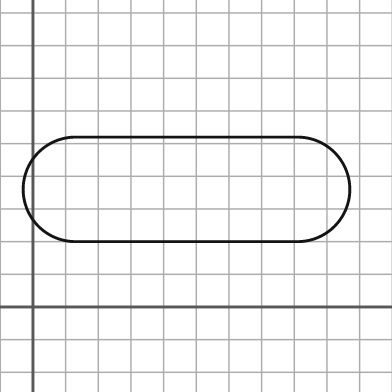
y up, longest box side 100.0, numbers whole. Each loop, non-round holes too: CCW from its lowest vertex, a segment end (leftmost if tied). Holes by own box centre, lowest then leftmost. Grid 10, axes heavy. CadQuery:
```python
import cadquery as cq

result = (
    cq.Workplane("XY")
    .moveTo(13.0, 20.0)
    .lineTo(81.0, 20.0)
    .threePointArc((97.0, 36.0), (81.0, 52.0))
    .lineTo(13.0, 52.0)
    .threePointArc((-3.0, 36.0), (13.0, 20.0))
    .close()
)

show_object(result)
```